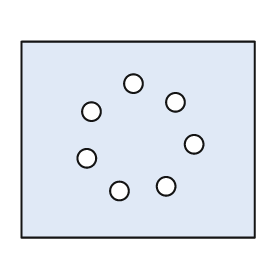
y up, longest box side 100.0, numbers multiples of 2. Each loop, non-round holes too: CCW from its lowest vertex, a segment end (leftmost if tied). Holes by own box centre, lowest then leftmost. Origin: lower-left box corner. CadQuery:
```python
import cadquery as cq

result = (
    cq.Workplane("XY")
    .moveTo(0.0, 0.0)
    .lineTo(100.0, 0.0)
    .lineTo(100.0, 84.0)
    .lineTo(0.0, 84.0)
    .close()
    .moveTo(42.0, 20.0)
    .circle(4.0)
    .moveTo(62.0, 22.0)
    .circle(4.0)
    .moveTo(28.0, 34.0)
    .circle(4.0)
    .moveTo(74.0, 40.0)
    .circle(4.0)
    .moveTo(30.0, 54.0)
    .circle(4.0)
    .moveTo(66.0, 58.0)
    .circle(4.0)
    .moveTo(48.0, 66.0)
    .circle(4.0)
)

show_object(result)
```